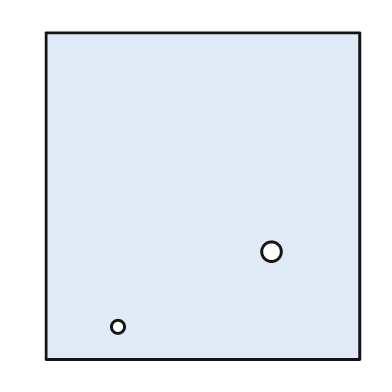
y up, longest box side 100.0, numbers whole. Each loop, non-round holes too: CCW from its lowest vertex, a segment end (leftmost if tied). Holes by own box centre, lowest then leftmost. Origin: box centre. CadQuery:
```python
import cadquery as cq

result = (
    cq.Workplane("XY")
    .moveTo(-48.0, -50.0)
    .lineTo(48.0, -50.0)
    .lineTo(48.0, 50.0)
    .lineTo(-48.0, 50.0)
    .close()
    .moveTo(-26.0, -40.0)
    .circle(2.0)
    .moveTo(21.0, -17.0)
    .circle(3.0)
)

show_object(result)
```